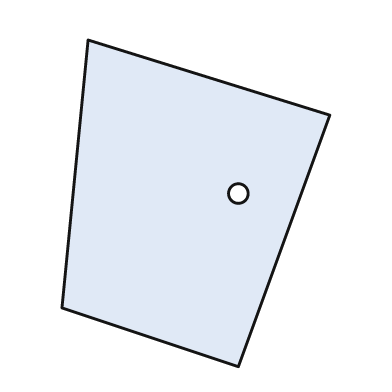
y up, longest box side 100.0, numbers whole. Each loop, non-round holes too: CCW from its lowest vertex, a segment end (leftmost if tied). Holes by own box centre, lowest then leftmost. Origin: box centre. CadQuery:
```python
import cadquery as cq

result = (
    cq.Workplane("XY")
    .moveTo(13.0, -50.0)
    .lineTo(41.0, 27.0)
    .lineTo(-33.0, 50.0)
    .lineTo(-41.0, -32.0)
    .close()
    .moveTo(13.0, 3.0)
    .circle(3.0)
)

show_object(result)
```